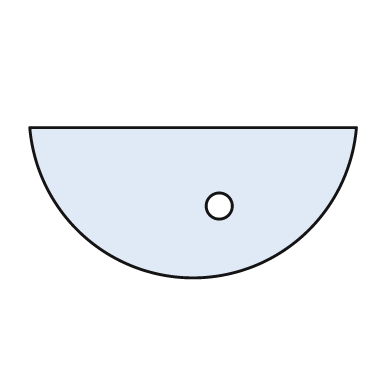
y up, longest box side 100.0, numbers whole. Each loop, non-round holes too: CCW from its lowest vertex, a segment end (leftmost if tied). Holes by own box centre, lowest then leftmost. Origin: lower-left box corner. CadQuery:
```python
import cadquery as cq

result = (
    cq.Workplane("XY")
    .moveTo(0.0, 46.0)
    .threePointArc((50.0, 0.0), (100.0, 46.0))
    .close()
    .moveTo(58.0, 22.0)
    .circle(4.0)
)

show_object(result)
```